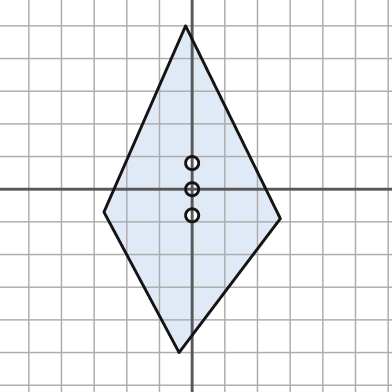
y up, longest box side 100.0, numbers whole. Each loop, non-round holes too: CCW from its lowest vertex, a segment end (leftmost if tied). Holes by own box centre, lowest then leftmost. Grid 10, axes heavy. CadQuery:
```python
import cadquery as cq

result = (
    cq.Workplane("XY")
    .moveTo(-4.0, -50.0)
    .lineTo(27.0, -9.0)
    .lineTo(-2.0, 50.0)
    .lineTo(-27.0, -7.0)
    .close()
    .moveTo(0.0, -8.0)
    .circle(2.0)
    .moveTo(0.0, 0.0)
    .circle(2.0)
    .moveTo(0.0, 8.0)
    .circle(2.0)
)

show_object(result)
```